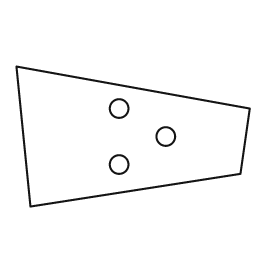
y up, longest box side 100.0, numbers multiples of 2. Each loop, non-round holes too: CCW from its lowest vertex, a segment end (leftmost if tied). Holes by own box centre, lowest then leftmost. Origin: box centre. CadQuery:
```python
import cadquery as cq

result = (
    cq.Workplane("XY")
    .moveTo(-44.0, -30.0)
    .lineTo(46.0, -16.0)
    .lineTo(50.0, 12.0)
    .lineTo(-50.0, 30.0)
    .close()
    .moveTo(-6.0, -12.0)
    .circle(4.0)
    .moveTo(14.0, 0.0)
    .circle(4.0)
    .moveTo(-6.0, 12.0)
    .circle(4.0)
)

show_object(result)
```